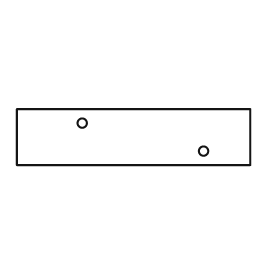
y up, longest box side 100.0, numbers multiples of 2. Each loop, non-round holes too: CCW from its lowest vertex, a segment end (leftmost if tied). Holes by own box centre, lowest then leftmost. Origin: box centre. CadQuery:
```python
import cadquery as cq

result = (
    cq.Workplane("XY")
    .moveTo(-50.0, -12.0)
    .lineTo(50.0, -12.0)
    .lineTo(50.0, 12.0)
    .lineTo(-50.0, 12.0)
    .close()
    .moveTo(30.0, -6.0)
    .circle(2.0)
    .moveTo(-22.0, 6.0)
    .circle(2.0)
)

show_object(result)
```